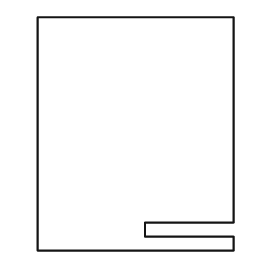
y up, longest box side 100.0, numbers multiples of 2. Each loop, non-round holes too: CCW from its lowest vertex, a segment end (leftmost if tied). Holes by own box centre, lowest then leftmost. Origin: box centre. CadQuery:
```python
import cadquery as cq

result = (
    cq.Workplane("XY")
    .moveTo(-42.0, -50.0)
    .lineTo(42.0, -50.0)
    .lineTo(42.0, -44.0)
    .lineTo(4.0, -44.0)
    .lineTo(4.0, -38.0)
    .lineTo(42.0, -38.0)
    .lineTo(42.0, 50.0)
    .lineTo(-42.0, 50.0)
    .close()
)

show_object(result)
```